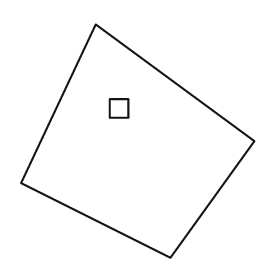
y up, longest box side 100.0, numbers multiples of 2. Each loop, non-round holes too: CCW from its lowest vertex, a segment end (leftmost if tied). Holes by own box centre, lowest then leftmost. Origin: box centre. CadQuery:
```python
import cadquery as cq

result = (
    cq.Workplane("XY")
    .moveTo(14.0, -50.0)
    .lineTo(50.0, 0.0)
    .lineTo(-18.0, 50.0)
    .lineTo(-50.0, -18.0)
    .close()
    .moveTo(-12.0, 10.0)
    .lineTo(-4.0, 10.0)
    .lineTo(-4.0, 18.0)
    .lineTo(-12.0, 18.0)
    .close()
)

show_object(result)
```